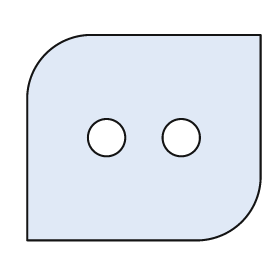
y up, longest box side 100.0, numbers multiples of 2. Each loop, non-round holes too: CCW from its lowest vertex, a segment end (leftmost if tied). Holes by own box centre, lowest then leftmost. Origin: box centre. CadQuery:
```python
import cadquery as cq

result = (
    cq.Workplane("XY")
    .moveTo(-50.0, -44.0)
    .lineTo(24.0, -44.0)
    .threePointArc((42.0, -36.0), (50.0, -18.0))
    .lineTo(50.0, 44.0)
    .lineTo(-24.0, 44.0)
    .threePointArc((-42.0, 36.0), (-50.0, 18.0))
    .close()
    .moveTo(-16.0, 0.0)
    .circle(8.0)
    .moveTo(16.0, 0.0)
    .circle(8.0)
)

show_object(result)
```